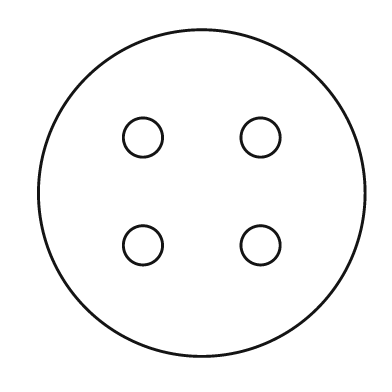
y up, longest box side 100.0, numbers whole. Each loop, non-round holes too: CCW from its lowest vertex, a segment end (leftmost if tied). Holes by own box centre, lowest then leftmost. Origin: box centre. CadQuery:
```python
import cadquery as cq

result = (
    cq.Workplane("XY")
    .moveTo(0.0, 0.0)
    .circle(50.0)
    .moveTo(-18.0, -16.0)
    .circle(6.0)
    .moveTo(18.0, -16.0)
    .circle(6.0)
    .moveTo(-18.0, 17.0)
    .circle(6.0)
    .moveTo(18.0, 17.0)
    .circle(6.0)
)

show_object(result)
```